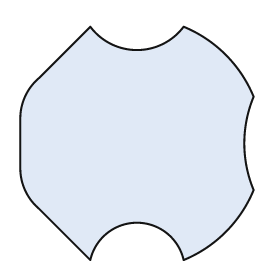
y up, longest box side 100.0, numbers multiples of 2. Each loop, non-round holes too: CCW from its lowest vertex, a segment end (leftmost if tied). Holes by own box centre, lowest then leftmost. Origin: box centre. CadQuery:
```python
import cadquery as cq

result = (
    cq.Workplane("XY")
    .moveTo(-20.0, -50.0)
    .threePointArc((0.0, -34.0), (20.0, -50.0))
    .threePointArc((38.0, -38.0), (50.0, -20.0))
    .threePointArc((46.0, 0.0), (50.0, 20.0))
    .threePointArc((38.0, 38.0), (20.0, 50.0))
    .threePointArc((0.0, 40.0), (-20.0, 50.0))
    .lineTo(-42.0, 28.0)
    .threePointArc((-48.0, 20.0), (-50.0, 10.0))
    .lineTo(-50.0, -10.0)
    .threePointArc((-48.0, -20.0), (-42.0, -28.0))
    .close()
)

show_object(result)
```